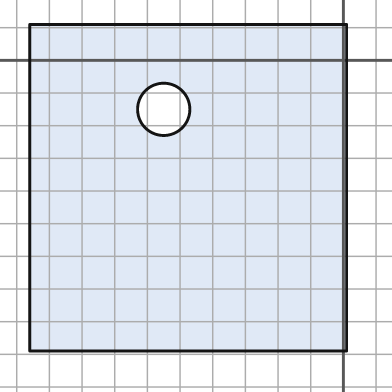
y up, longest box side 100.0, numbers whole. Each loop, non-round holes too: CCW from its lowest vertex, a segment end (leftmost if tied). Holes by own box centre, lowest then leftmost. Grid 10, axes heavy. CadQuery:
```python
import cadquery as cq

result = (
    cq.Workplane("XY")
    .moveTo(-96.0, -89.0)
    .lineTo(1.0, -89.0)
    .lineTo(1.0, 11.0)
    .lineTo(-96.0, 11.0)
    .close()
    .moveTo(-55.0, -15.0)
    .circle(8.0)
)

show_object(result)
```